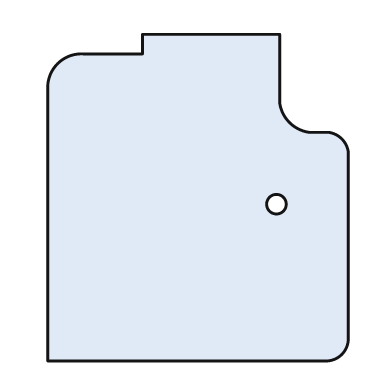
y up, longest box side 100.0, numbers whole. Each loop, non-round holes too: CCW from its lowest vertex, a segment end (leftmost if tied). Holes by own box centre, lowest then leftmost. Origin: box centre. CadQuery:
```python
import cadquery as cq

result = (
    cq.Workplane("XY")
    .moveTo(-46.0, -50.0)
    .lineTo(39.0, -50.0)
    .threePointArc((44.0, -48.0), (46.0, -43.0))
    .lineTo(46.0, 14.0)
    .threePointArc((44.0, 18.0), (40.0, 20.0))
    .lineTo(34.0, 20.0)
    .threePointArc((28.0, 23.0), (25.0, 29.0))
    .lineTo(25.0, 50.0)
    .lineTo(-17.0, 50.0)
    .lineTo(-17.0, 44.0)
    .lineTo(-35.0, 44.0)
    .threePointArc((-43.0, 41.0), (-46.0, 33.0))
    .close()
    .moveTo(24.0, -2.0)
    .circle(3.0)
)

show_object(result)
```